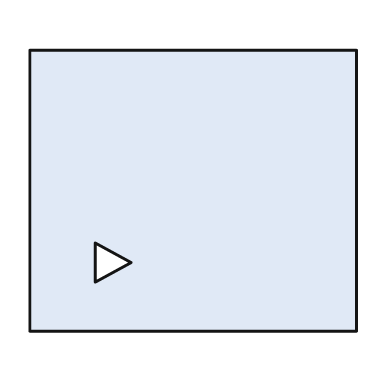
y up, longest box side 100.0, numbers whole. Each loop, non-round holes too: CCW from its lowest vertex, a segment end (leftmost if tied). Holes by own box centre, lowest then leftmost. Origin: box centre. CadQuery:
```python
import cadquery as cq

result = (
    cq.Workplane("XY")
    .moveTo(-50.0, -43.0)
    .lineTo(50.0, -43.0)
    .lineTo(50.0, 43.0)
    .lineTo(-50.0, 43.0)
    .close()
    .moveTo(-30.0, -28.0)
    .lineTo(-19.0, -22.0)
    .lineTo(-30.0, -16.0)
    .close()
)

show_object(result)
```